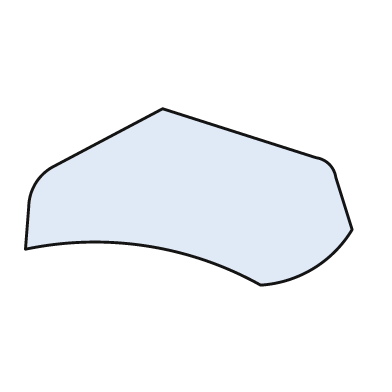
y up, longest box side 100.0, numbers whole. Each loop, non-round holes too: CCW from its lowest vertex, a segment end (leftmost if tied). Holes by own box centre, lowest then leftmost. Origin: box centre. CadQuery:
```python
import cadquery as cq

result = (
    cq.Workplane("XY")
    .moveTo(22.0, -27.0)
    .threePointArc((38.0, -22.0), (50.0, -10.0))
    .lineTo(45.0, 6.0)
    .threePointArc((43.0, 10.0), (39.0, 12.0))
    .lineTo(-8.0, 27.0)
    .lineTo(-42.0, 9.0)
    .threePointArc((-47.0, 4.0), (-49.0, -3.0))
    .lineTo(-50.0, -16.0)
    .threePointArc((-13.0, -15.0), (22.0, -27.0))
    .close()
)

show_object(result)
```